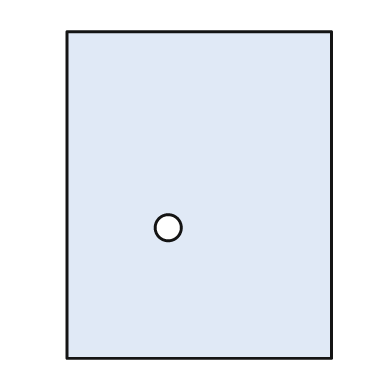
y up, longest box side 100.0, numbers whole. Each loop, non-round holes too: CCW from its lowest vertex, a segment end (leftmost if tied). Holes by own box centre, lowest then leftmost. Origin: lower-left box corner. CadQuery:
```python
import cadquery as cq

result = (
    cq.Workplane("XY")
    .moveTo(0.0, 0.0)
    .lineTo(81.0, 0.0)
    .lineTo(81.0, 100.0)
    .lineTo(0.0, 100.0)
    .close()
    .moveTo(31.0, 40.0)
    .circle(4.0)
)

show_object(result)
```